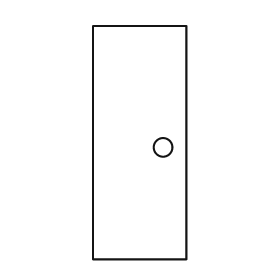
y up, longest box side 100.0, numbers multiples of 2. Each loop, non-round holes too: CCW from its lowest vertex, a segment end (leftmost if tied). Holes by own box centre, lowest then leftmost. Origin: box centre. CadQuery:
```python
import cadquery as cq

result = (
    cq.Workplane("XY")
    .moveTo(-20.0, -50.0)
    .lineTo(20.0, -50.0)
    .lineTo(20.0, 50.0)
    .lineTo(-20.0, 50.0)
    .close()
    .moveTo(10.0, -2.0)
    .circle(4.0)
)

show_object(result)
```